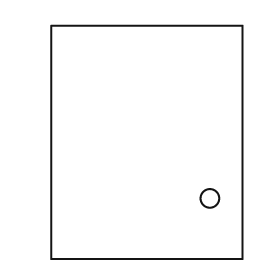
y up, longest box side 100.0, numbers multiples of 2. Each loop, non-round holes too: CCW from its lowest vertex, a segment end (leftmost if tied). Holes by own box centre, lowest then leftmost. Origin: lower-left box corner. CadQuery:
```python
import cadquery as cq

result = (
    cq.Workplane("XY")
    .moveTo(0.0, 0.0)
    .lineTo(82.0, 0.0)
    .lineTo(82.0, 100.0)
    .lineTo(0.0, 100.0)
    .close()
    .moveTo(68.0, 26.0)
    .circle(4.0)
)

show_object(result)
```